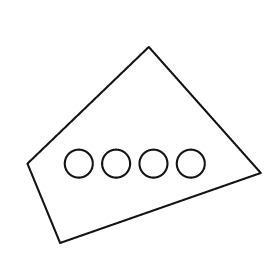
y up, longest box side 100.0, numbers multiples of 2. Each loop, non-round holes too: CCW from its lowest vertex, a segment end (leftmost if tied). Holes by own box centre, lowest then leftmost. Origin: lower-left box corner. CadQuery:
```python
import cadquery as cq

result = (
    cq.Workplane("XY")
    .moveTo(14.0, 0.0)
    .lineTo(100.0, 30.0)
    .lineTo(52.0, 84.0)
    .lineTo(0.0, 34.0)
    .close()
    .moveTo(22.0, 34.0)
    .circle(6.0)
    .moveTo(38.0, 34.0)
    .circle(6.0)
    .moveTo(54.0, 34.0)
    .circle(6.0)
    .moveTo(70.0, 34.0)
    .circle(6.0)
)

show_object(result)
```